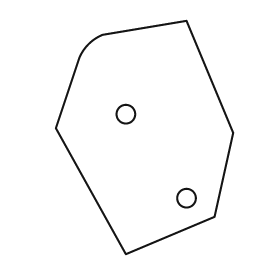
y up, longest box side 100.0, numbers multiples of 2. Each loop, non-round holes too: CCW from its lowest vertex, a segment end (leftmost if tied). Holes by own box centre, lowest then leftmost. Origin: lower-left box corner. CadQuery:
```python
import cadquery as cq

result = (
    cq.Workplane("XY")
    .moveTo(30.0, 0.0)
    .lineTo(68.0, 16.0)
    .lineTo(76.0, 52.0)
    .lineTo(56.0, 100.0)
    .lineTo(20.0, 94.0)
    .threePointArc((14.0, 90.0), (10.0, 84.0))
    .lineTo(0.0, 54.0)
    .close()
    .moveTo(56.0, 24.0)
    .circle(4.0)
    .moveTo(30.0, 60.0)
    .circle(4.0)
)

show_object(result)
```